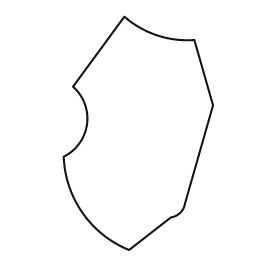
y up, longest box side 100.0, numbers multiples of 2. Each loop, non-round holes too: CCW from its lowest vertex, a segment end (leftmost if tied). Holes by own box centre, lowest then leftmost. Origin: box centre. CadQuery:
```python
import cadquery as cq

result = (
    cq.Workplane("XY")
    .moveTo(-4.0, -50.0)
    .lineTo(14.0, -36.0)
    .threePointArc((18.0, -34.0), (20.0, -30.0))
    .lineTo(32.0, 12.0)
    .lineTo(24.0, 40.0)
    .threePointArc((8.0, 42.0), (-6.0, 50.0))
    .lineTo(-28.0, 20.0)
    .threePointArc((-22.0, 4.0), (-32.0, -10.0))
    .threePointArc((-24.0, -34.0), (-4.0, -50.0))
    .close()
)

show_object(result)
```